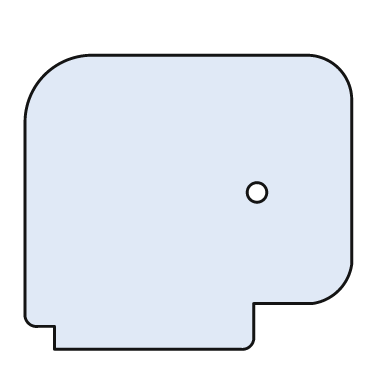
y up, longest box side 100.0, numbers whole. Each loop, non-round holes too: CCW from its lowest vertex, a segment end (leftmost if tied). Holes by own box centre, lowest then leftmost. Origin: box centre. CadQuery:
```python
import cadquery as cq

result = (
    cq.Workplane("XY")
    .moveTo(-41.0, -45.0)
    .lineTo(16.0, -45.0)
    .threePointArc((19.0, -44.0), (20.0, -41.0))
    .lineTo(20.0, -31.0)
    .lineTo(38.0, -31.0)
    .threePointArc((46.0, -27.0), (50.0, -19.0))
    .lineTo(50.0, 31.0)
    .threePointArc((46.0, 41.0), (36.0, 45.0))
    .lineTo(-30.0, 45.0)
    .threePointArc((-44.0, 39.0), (-50.0, 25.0))
    .lineTo(-50.0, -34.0)
    .threePointArc((-49.0, -37.0), (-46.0, -38.0))
    .lineTo(-41.0, -38.0)
    .close()
    .moveTo(21.0, 3.0)
    .circle(3.0)
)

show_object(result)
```